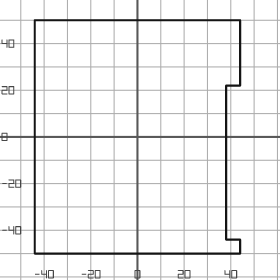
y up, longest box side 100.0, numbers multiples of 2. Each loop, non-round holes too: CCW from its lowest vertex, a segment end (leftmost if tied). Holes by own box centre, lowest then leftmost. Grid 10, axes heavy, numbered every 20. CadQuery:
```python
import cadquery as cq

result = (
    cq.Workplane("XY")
    .moveTo(-44.0, -50.0)
    .lineTo(44.0, -50.0)
    .lineTo(44.0, -44.0)
    .lineTo(38.0, -44.0)
    .lineTo(38.0, 22.0)
    .lineTo(44.0, 22.0)
    .lineTo(44.0, 50.0)
    .lineTo(-44.0, 50.0)
    .close()
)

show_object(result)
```